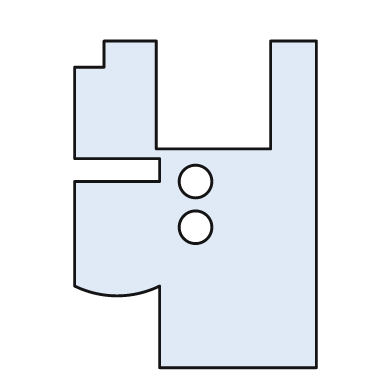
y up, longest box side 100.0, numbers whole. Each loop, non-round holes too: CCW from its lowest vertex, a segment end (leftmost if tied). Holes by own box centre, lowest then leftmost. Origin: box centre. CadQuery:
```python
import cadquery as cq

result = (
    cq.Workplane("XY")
    .moveTo(-11.0, -50.0)
    .lineTo(37.0, -50.0)
    .lineTo(37.0, 50.0)
    .lineTo(23.0, 50.0)
    .lineTo(23.0, 17.0)
    .lineTo(-12.0, 17.0)
    .lineTo(-12.0, 50.0)
    .lineTo(-28.0, 50.0)
    .lineTo(-28.0, 42.0)
    .lineTo(-37.0, 42.0)
    .lineTo(-37.0, 14.0)
    .lineTo(-11.0, 14.0)
    .lineTo(-11.0, 7.0)
    .lineTo(-37.0, 7.0)
    .lineTo(-37.0, -25.0)
    .threePointArc((-24.0, -28.0), (-11.0, -25.0))
    .close()
    .moveTo(0.0, -7.0)
    .circle(5.0)
    .moveTo(0.0, 7.0)
    .circle(5.0)
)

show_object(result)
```